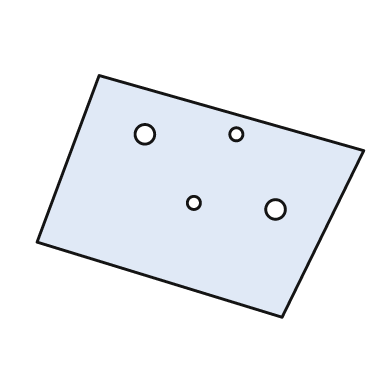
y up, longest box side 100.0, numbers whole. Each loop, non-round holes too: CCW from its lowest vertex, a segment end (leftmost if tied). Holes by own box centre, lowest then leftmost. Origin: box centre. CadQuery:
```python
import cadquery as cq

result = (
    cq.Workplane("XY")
    .moveTo(25.0, -37.0)
    .lineTo(50.0, 14.0)
    .lineTo(-31.0, 37.0)
    .lineTo(-50.0, -14.0)
    .close()
    .moveTo(23.0, -4.0)
    .circle(3.0)
    .moveTo(-2.0, -2.0)
    .circle(2.0)
    .moveTo(-17.0, 19.0)
    .circle(3.0)
    .moveTo(11.0, 19.0)
    .circle(2.0)
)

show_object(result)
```